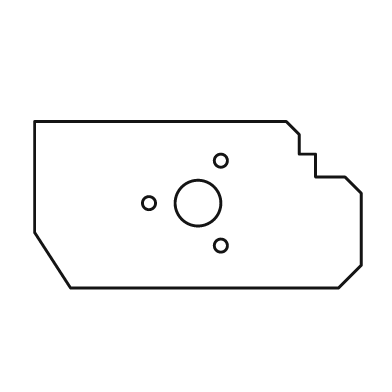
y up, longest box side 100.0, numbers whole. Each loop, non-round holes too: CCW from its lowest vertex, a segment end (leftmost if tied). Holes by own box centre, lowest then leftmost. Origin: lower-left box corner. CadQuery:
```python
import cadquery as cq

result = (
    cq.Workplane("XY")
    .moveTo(11.0, 0.0)
    .lineTo(93.0, 0.0)
    .lineTo(100.0, 7.0)
    .lineTo(100.0, 29.0)
    .lineTo(95.0, 34.0)
    .lineTo(86.0, 34.0)
    .lineTo(86.0, 41.0)
    .lineTo(81.0, 41.0)
    .lineTo(81.0, 47.0)
    .lineTo(77.0, 51.0)
    .lineTo(0.0, 51.0)
    .lineTo(0.0, 17.0)
    .close()
    .moveTo(57.0, 13.0)
    .circle(2.0)
    .moveTo(35.0, 26.0)
    .circle(2.0)
    .moveTo(50.0, 26.0)
    .circle(7.0)
    .moveTo(57.0, 39.0)
    .circle(2.0)
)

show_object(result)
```